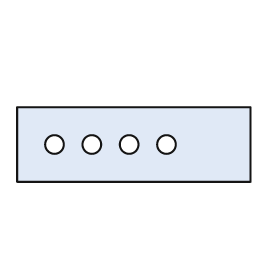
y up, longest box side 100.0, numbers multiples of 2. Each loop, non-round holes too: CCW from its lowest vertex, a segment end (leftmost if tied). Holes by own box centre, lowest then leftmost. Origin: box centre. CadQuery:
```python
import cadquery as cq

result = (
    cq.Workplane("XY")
    .moveTo(-50.0, -16.0)
    .lineTo(50.0, -16.0)
    .lineTo(50.0, 16.0)
    .lineTo(-50.0, 16.0)
    .close()
    .moveTo(-34.0, 0.0)
    .circle(4.0)
    .moveTo(-18.0, 0.0)
    .circle(4.0)
    .moveTo(-2.0, 0.0)
    .circle(4.0)
    .moveTo(14.0, 0.0)
    .circle(4.0)
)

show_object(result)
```